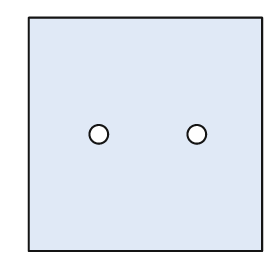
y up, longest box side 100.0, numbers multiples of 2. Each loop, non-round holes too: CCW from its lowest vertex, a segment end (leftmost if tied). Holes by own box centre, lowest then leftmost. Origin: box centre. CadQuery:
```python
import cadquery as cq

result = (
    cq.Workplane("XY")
    .moveTo(-50.0, -50.0)
    .lineTo(50.0, -50.0)
    .lineTo(50.0, 50.0)
    .lineTo(-50.0, 50.0)
    .close()
    .moveTo(-20.0, 0.0)
    .circle(4.0)
    .moveTo(22.0, 0.0)
    .circle(4.0)
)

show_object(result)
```